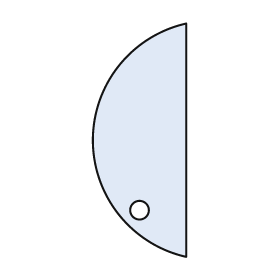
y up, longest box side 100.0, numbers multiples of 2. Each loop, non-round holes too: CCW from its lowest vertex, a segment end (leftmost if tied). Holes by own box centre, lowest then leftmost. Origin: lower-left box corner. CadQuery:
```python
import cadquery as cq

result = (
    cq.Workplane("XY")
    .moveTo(40.0, 0.0)
    .lineTo(40.0, 100.0)
    .threePointArc((0.0, 50.0), (40.0, 0.0))
    .close()
    .moveTo(20.0, 20.0)
    .circle(4.0)
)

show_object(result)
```